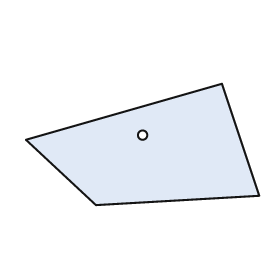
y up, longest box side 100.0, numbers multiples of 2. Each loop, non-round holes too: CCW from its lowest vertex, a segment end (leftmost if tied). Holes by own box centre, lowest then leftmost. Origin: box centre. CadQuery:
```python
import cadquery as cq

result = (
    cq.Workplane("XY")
    .moveTo(-20.0, -26.0)
    .lineTo(50.0, -22.0)
    .lineTo(34.0, 26.0)
    .lineTo(-50.0, 2.0)
    .close()
    .moveTo(0.0, 4.0)
    .circle(2.0)
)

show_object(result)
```